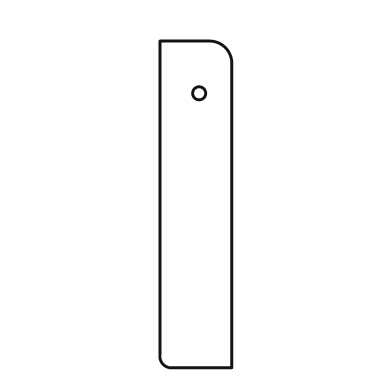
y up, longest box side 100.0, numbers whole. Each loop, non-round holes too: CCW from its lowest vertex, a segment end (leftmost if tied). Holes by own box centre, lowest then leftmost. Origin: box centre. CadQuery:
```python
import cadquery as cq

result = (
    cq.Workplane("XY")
    .moveTo(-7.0, -50.0)
    .lineTo(11.0, -50.0)
    .lineTo(11.0, 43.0)
    .threePointArc((9.0, 48.0), (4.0, 50.0))
    .lineTo(-11.0, 50.0)
    .lineTo(-11.0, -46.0)
    .threePointArc((-10.0, -49.0), (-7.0, -50.0))
    .close()
    .moveTo(1.0, 34.0)
    .circle(2.0)
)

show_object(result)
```